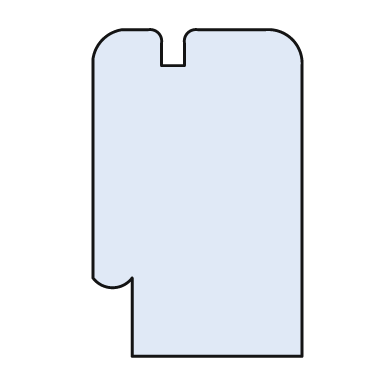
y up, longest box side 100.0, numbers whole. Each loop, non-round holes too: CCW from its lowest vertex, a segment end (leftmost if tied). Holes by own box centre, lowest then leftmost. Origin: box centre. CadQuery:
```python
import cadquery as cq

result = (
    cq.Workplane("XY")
    .moveTo(-20.0, -50.0)
    .lineTo(32.0, -50.0)
    .lineTo(32.0, 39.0)
    .threePointArc((29.0, 47.0), (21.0, 50.0))
    .lineTo(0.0, 50.0)
    .threePointArc((-3.0, 49.0), (-4.0, 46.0))
    .lineTo(-4.0, 39.0)
    .lineTo(-11.0, 39.0)
    .lineTo(-11.0, 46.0)
    .threePointArc((-12.0, 49.0), (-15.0, 50.0))
    .lineTo(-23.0, 50.0)
    .threePointArc((-29.0, 47.0), (-32.0, 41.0))
    .lineTo(-32.0, -26.0)
    .threePointArc((-26.0, -29.0), (-20.0, -26.0))
    .close()
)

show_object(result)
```